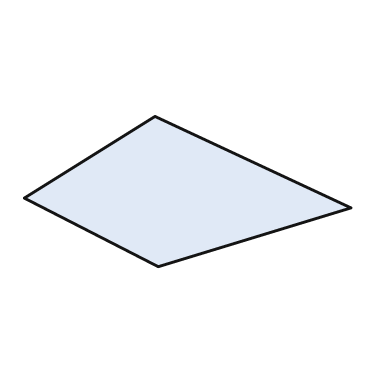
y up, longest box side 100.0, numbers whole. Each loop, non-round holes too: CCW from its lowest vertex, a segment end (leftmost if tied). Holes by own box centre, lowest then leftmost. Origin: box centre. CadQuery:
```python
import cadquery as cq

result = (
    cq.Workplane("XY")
    .moveTo(-9.0, -23.0)
    .lineTo(50.0, -5.0)
    .lineTo(-10.0, 23.0)
    .lineTo(-50.0, -2.0)
    .close()
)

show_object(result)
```